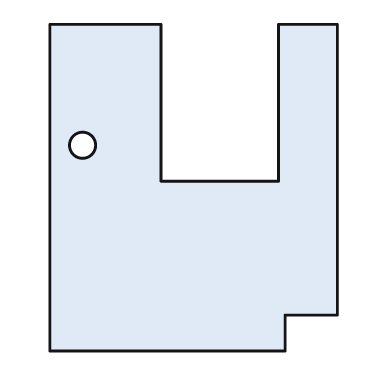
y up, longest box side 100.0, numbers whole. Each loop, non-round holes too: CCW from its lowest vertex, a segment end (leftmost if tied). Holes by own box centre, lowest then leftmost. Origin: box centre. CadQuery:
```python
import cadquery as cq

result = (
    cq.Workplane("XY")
    .moveTo(-44.0, -50.0)
    .lineTo(28.0, -50.0)
    .lineTo(28.0, -39.0)
    .lineTo(44.0, -39.0)
    .lineTo(44.0, 50.0)
    .lineTo(26.0, 50.0)
    .lineTo(26.0, 2.0)
    .lineTo(-10.0, 2.0)
    .lineTo(-10.0, 50.0)
    .lineTo(-44.0, 50.0)
    .close()
    .moveTo(-34.0, 13.0)
    .circle(4.0)
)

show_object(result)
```